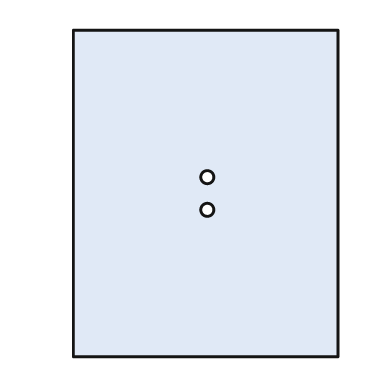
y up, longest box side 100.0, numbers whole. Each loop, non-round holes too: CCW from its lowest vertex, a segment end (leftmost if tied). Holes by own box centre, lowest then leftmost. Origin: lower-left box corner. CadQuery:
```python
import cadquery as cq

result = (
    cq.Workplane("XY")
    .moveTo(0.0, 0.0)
    .lineTo(81.0, 0.0)
    .lineTo(81.0, 100.0)
    .lineTo(0.0, 100.0)
    .close()
    .moveTo(41.0, 45.0)
    .circle(2.0)
    .moveTo(41.0, 55.0)
    .circle(2.0)
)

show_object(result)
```